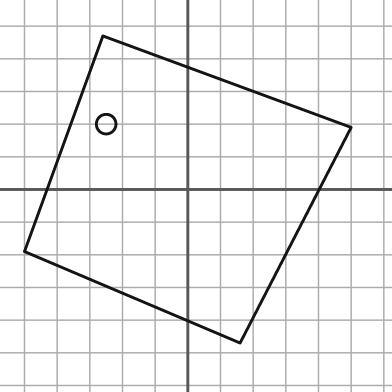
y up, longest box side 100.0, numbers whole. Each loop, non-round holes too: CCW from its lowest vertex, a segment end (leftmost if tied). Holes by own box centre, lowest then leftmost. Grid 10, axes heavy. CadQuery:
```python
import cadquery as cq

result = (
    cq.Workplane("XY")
    .moveTo(16.0, -47.0)
    .lineTo(50.0, 19.0)
    .lineTo(-26.0, 47.0)
    .lineTo(-50.0, -19.0)
    .close()
    .moveTo(-25.0, 20.0)
    .circle(3.0)
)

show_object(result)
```